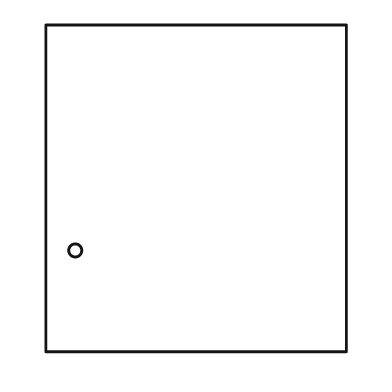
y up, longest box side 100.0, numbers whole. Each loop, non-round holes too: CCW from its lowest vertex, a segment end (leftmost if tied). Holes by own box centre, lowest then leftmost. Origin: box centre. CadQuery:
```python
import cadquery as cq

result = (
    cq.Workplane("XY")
    .moveTo(-46.0, -50.0)
    .lineTo(46.0, -50.0)
    .lineTo(46.0, 50.0)
    .lineTo(-46.0, 50.0)
    .close()
    .moveTo(-37.0, -19.0)
    .circle(2.0)
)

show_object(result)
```